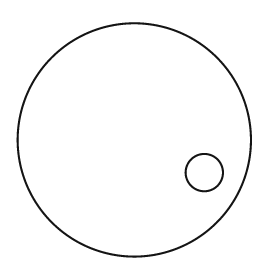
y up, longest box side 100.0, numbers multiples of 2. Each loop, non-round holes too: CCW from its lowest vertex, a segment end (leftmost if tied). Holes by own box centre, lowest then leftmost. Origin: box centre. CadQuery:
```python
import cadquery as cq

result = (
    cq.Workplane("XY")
    .moveTo(0.0, 0.0)
    .circle(50.0)
    .moveTo(30.0, -14.0)
    .circle(8.0)
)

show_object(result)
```